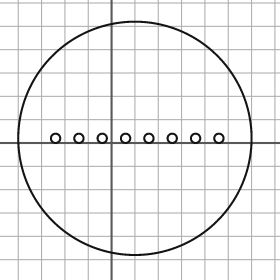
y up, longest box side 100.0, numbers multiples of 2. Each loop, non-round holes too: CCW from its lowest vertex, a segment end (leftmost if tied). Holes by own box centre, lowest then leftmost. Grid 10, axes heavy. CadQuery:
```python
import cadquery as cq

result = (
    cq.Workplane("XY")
    .moveTo(10.0, 2.0)
    .circle(50.0)
    .moveTo(-24.0, 2.0)
    .circle(2.0)
    .moveTo(-14.0, 2.0)
    .circle(2.0)
    .moveTo(-4.0, 2.0)
    .circle(2.0)
    .moveTo(6.0, 2.0)
    .circle(2.0)
    .moveTo(16.0, 2.0)
    .circle(2.0)
    .moveTo(26.0, 2.0)
    .circle(2.0)
    .moveTo(36.0, 2.0)
    .circle(2.0)
    .moveTo(46.0, 2.0)
    .circle(2.0)
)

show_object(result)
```